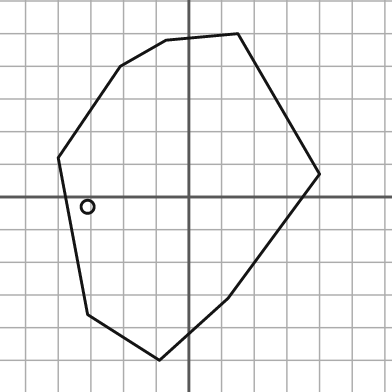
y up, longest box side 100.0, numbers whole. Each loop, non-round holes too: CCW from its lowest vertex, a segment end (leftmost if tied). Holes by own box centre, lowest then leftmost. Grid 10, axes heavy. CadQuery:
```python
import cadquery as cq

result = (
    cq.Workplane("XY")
    .moveTo(-9.0, -50.0)
    .lineTo(12.0, -31.0)
    .lineTo(40.0, 7.0)
    .lineTo(15.0, 50.0)
    .lineTo(-7.0, 48.0)
    .lineTo(-21.0, 40.0)
    .lineTo(-40.0, 12.0)
    .lineTo(-31.0, -36.0)
    .close()
    .moveTo(-31.0, -3.0)
    .circle(2.0)
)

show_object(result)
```